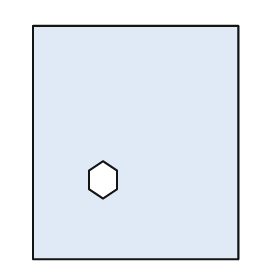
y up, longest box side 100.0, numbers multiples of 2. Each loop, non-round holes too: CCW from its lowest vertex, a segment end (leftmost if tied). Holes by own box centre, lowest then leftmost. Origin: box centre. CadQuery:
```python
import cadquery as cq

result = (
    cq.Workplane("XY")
    .moveTo(-44.0, -50.0)
    .lineTo(44.0, -50.0)
    .lineTo(44.0, 50.0)
    .lineTo(-44.0, 50.0)
    .close()
    .moveTo(-14.0, -24.0)
    .lineTo(-8.0, -20.0)
    .lineTo(-8.0, -12.0)
    .lineTo(-14.0, -8.0)
    .lineTo(-20.0, -12.0)
    .lineTo(-20.0, -20.0)
    .close()
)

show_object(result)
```